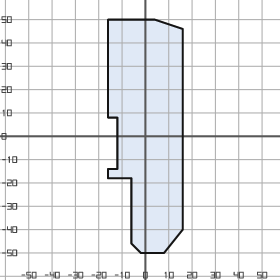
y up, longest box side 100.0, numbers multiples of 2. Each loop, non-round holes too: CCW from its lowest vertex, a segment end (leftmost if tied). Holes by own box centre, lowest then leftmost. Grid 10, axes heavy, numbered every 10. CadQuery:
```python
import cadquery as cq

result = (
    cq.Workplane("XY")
    .moveTo(-2.0, -50.0)
    .lineTo(8.0, -50.0)
    .lineTo(16.0, -40.0)
    .lineTo(16.0, 46.0)
    .lineTo(4.0, 50.0)
    .lineTo(-16.0, 50.0)
    .lineTo(-16.0, 8.0)
    .lineTo(-12.0, 8.0)
    .lineTo(-12.0, -14.0)
    .lineTo(-16.0, -14.0)
    .lineTo(-16.0, -18.0)
    .lineTo(-6.0, -18.0)
    .lineTo(-6.0, -46.0)
    .close()
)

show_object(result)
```